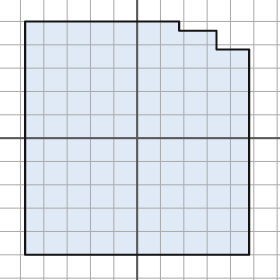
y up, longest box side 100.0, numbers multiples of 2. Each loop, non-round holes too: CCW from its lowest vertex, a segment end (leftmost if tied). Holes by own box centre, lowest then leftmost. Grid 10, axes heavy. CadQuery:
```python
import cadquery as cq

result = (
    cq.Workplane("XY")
    .moveTo(-48.0, -50.0)
    .lineTo(48.0, -50.0)
    .lineTo(48.0, 38.0)
    .lineTo(34.0, 38.0)
    .lineTo(34.0, 46.0)
    .lineTo(18.0, 46.0)
    .lineTo(18.0, 50.0)
    .lineTo(-48.0, 50.0)
    .close()
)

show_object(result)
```